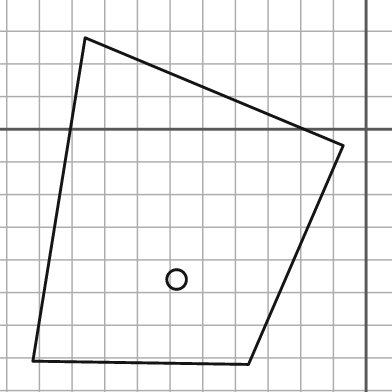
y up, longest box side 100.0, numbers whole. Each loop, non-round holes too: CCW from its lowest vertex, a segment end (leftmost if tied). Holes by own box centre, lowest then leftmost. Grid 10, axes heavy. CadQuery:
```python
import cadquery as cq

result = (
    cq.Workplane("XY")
    .moveTo(-36.0, -72.0)
    .lineTo(-7.0, -5.0)
    .lineTo(-86.0, 28.0)
    .lineTo(-102.0, -71.0)
    .close()
    .moveTo(-58.0, -46.0)
    .circle(3.0)
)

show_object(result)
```